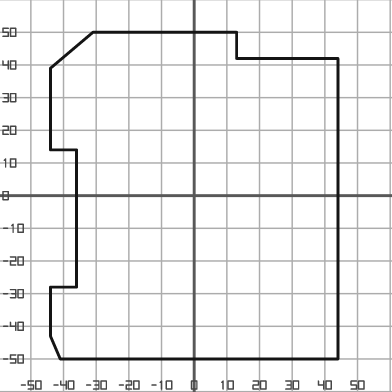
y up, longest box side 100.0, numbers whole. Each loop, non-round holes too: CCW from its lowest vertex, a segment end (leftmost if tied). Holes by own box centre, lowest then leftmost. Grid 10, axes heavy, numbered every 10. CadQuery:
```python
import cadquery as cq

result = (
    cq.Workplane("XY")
    .moveTo(-41.0, -50.0)
    .lineTo(44.0, -50.0)
    .lineTo(44.0, 42.0)
    .lineTo(13.0, 42.0)
    .lineTo(13.0, 50.0)
    .lineTo(-31.0, 50.0)
    .lineTo(-44.0, 39.0)
    .lineTo(-44.0, 14.0)
    .lineTo(-36.0, 14.0)
    .lineTo(-36.0, -28.0)
    .lineTo(-44.0, -28.0)
    .lineTo(-44.0, -43.0)
    .close()
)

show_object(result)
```